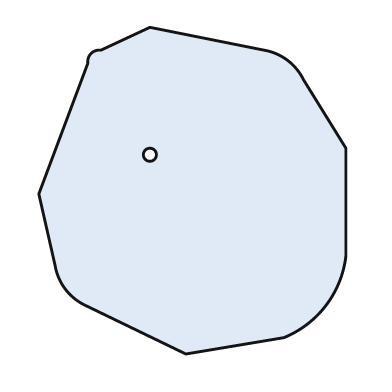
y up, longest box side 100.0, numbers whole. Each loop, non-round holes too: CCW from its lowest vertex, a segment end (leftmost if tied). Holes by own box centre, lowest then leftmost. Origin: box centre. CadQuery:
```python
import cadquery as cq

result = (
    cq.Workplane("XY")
    .moveTo(-2.0, -50.0)
    .lineTo(28.0, -45.0)
    .threePointArc((41.0, -35.0), (47.0, -20.0))
    .lineTo(47.0, 13.0)
    .lineTo(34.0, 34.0)
    .threePointArc((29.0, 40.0), (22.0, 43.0))
    .lineTo(-13.0, 50.0)
    .lineTo(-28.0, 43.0)
    .threePointArc((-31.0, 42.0), (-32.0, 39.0))
    .lineTo(-47.0, -1.0)
    .lineTo(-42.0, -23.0)
    .threePointArc((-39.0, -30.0), (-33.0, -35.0))
    .close()
    .moveTo(-13.0, 11.0)
    .circle(2.0)
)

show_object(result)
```